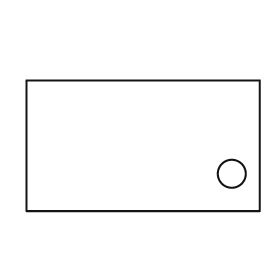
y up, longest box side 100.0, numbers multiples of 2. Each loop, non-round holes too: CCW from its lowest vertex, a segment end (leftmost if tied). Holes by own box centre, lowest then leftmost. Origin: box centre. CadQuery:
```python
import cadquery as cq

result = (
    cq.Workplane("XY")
    .moveTo(-50.0, -28.0)
    .lineTo(50.0, -28.0)
    .lineTo(50.0, 28.0)
    .lineTo(-50.0, 28.0)
    .close()
    .moveTo(38.0, -12.0)
    .circle(6.0)
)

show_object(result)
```